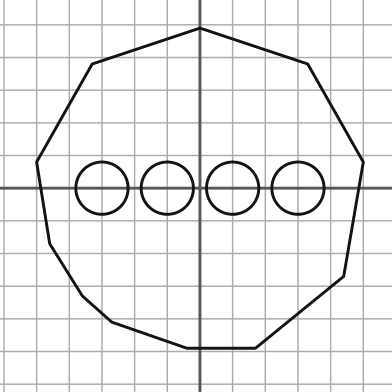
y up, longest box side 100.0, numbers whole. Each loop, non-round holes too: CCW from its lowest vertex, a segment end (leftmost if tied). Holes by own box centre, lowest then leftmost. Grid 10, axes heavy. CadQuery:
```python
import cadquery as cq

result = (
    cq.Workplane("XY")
    .moveTo(-4.0, -49.0)
    .lineTo(17.0, -49.0)
    .lineTo(44.0, -27.0)
    .lineTo(50.0, 8.0)
    .lineTo(33.0, 38.0)
    .lineTo(0.0, 49.0)
    .lineTo(-33.0, 38.0)
    .lineTo(-50.0, 8.0)
    .lineTo(-46.0, -17.0)
    .lineTo(-36.0, -33.0)
    .lineTo(-27.0, -41.0)
    .close()
    .moveTo(-30.0, 0.0)
    .circle(8.0)
    .moveTo(-10.0, 0.0)
    .circle(8.0)
    .moveTo(10.0, 0.0)
    .circle(8.0)
    .moveTo(30.0, 0.0)
    .circle(8.0)
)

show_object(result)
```